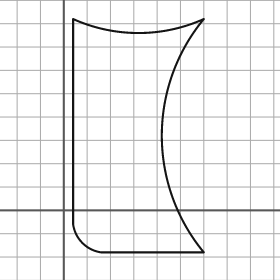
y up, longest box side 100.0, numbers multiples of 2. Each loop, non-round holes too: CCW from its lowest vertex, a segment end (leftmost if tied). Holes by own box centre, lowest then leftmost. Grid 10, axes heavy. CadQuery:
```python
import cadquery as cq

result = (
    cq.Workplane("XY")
    .moveTo(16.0, -18.0)
    .lineTo(60.0, -18.0)
    .threePointArc((42.0, 32.0), (60.0, 82.0))
    .threePointArc((32.0, 76.0), (4.0, 82.0))
    .lineTo(4.0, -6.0)
    .threePointArc((8.0, -14.0), (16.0, -18.0))
    .close()
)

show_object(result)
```